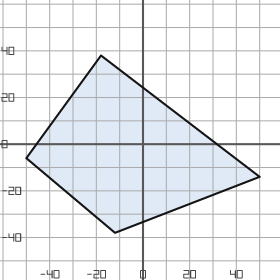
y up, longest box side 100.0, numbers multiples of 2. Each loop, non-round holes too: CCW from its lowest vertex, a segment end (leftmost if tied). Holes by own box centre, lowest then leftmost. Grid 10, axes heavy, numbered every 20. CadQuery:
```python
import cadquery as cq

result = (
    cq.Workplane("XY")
    .moveTo(-12.0, -38.0)
    .lineTo(50.0, -14.0)
    .lineTo(-18.0, 38.0)
    .lineTo(-50.0, -6.0)
    .close()
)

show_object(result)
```